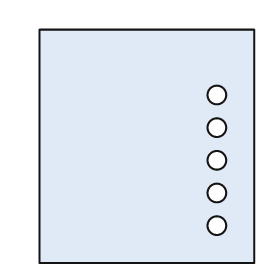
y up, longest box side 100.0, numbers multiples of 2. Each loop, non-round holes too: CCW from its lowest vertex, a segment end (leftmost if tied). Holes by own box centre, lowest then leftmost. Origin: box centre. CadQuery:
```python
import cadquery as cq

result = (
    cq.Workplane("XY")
    .moveTo(-46.0, -50.0)
    .lineTo(46.0, -50.0)
    .lineTo(46.0, 50.0)
    .lineTo(-46.0, 50.0)
    .close()
    .moveTo(30.0, -34.0)
    .circle(4.0)
    .moveTo(30.0, -20.0)
    .circle(4.0)
    .moveTo(30.0, -6.0)
    .circle(4.0)
    .moveTo(30.0, 8.0)
    .circle(4.0)
    .moveTo(30.0, 22.0)
    .circle(4.0)
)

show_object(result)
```